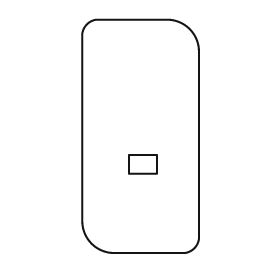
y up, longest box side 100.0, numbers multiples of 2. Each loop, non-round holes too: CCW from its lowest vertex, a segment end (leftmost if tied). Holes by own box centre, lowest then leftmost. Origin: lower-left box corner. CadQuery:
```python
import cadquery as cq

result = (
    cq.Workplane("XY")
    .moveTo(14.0, 0.0)
    .lineTo(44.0, 0.0)
    .threePointArc((48.0, 2.0), (50.0, 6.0))
    .lineTo(50.0, 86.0)
    .threePointArc((46.0, 96.0), (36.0, 100.0))
    .lineTo(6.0, 100.0)
    .threePointArc((2.0, 98.0), (0.0, 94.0))
    .lineTo(0.0, 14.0)
    .threePointArc((4.0, 4.0), (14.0, 0.0))
    .close()
    .moveTo(20.0, 34.0)
    .lineTo(32.0, 34.0)
    .lineTo(32.0, 42.0)
    .lineTo(20.0, 42.0)
    .close()
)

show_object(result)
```